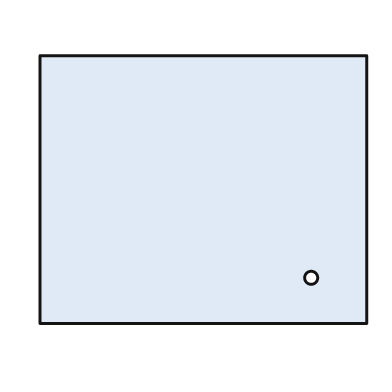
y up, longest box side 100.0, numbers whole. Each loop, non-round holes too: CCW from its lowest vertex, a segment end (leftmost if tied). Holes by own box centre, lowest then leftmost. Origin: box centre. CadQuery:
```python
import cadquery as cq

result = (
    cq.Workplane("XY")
    .moveTo(-50.0, -41.0)
    .lineTo(50.0, -41.0)
    .lineTo(50.0, 41.0)
    .lineTo(-50.0, 41.0)
    .close()
    .moveTo(33.0, -27.0)
    .circle(2.0)
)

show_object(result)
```